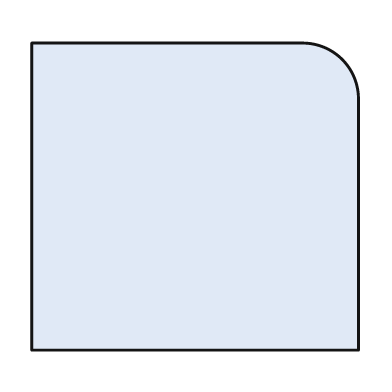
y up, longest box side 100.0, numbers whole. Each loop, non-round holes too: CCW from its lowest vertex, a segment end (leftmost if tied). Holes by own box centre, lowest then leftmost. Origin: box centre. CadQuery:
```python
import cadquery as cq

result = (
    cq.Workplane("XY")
    .moveTo(-50.0, -47.0)
    .lineTo(50.0, -47.0)
    .lineTo(50.0, 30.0)
    .threePointArc((45.0, 42.0), (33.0, 47.0))
    .lineTo(-50.0, 47.0)
    .close()
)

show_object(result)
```